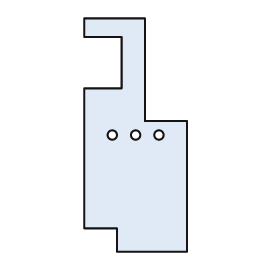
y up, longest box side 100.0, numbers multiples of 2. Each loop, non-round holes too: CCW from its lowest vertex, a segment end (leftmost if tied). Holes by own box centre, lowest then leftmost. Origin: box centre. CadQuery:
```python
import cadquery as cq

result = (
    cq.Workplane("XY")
    .moveTo(-8.0, -50.0)
    .lineTo(22.0, -50.0)
    .lineTo(22.0, 6.0)
    .lineTo(4.0, 6.0)
    .lineTo(4.0, 50.0)
    .lineTo(-22.0, 50.0)
    .lineTo(-22.0, 42.0)
    .lineTo(-6.0, 42.0)
    .lineTo(-6.0, 20.0)
    .lineTo(-22.0, 20.0)
    .lineTo(-22.0, -40.0)
    .lineTo(-8.0, -40.0)
    .close()
    .moveTo(-10.0, 0.0)
    .circle(2.0)
    .moveTo(0.0, 0.0)
    .circle(2.0)
    .moveTo(10.0, 0.0)
    .circle(2.0)
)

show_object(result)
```